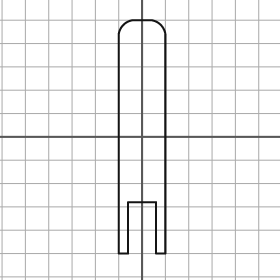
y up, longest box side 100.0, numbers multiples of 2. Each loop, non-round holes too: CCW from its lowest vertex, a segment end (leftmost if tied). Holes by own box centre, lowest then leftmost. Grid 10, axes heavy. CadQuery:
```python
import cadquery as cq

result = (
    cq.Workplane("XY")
    .moveTo(-10.0, -50.0)
    .lineTo(-6.0, -50.0)
    .lineTo(-6.0, -28.0)
    .lineTo(6.0, -28.0)
    .lineTo(6.0, -50.0)
    .lineTo(10.0, -50.0)
    .lineTo(10.0, 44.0)
    .threePointArc((8.0, 48.0), (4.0, 50.0))
    .lineTo(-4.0, 50.0)
    .threePointArc((-8.0, 48.0), (-10.0, 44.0))
    .close()
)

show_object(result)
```